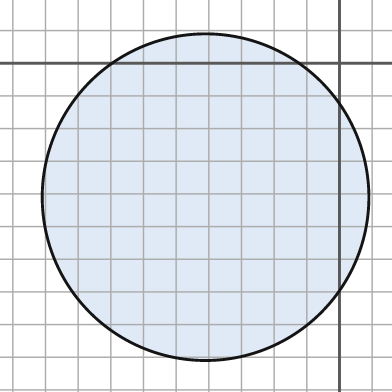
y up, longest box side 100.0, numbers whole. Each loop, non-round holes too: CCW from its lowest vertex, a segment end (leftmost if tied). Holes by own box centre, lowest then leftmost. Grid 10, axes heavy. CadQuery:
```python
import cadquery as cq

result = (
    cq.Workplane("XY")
    .moveTo(-41.0, -41.0)
    .circle(50.0)
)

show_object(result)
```